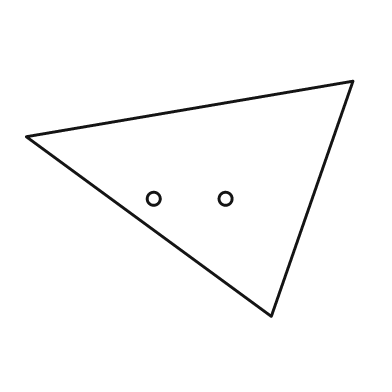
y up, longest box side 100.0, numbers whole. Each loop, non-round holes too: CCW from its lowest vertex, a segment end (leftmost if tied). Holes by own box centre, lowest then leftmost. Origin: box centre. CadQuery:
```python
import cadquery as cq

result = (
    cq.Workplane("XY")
    .moveTo(25.0, -36.0)
    .lineTo(50.0, 36.0)
    .lineTo(-50.0, 19.0)
    .close()
    .moveTo(-11.0, 0.0)
    .circle(2.0)
    .moveTo(11.0, 0.0)
    .circle(2.0)
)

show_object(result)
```